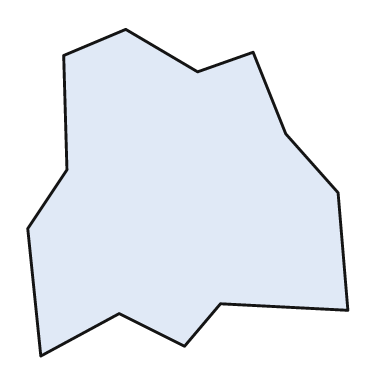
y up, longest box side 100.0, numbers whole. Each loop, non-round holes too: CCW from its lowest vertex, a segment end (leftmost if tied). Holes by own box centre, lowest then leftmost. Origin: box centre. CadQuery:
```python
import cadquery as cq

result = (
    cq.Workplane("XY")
    .moveTo(-45.0, -50.0)
    .lineTo(-21.0, -37.0)
    .lineTo(-1.0, -47.0)
    .lineTo(10.0, -34.0)
    .lineTo(49.0, -36.0)
    .lineTo(46.0, 0.0)
    .lineTo(30.0, 18.0)
    .lineTo(20.0, 43.0)
    .lineTo(3.0, 37.0)
    .lineTo(-19.0, 50.0)
    .lineTo(-38.0, 42.0)
    .lineTo(-37.0, 7.0)
    .lineTo(-49.0, -11.0)
    .close()
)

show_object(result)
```